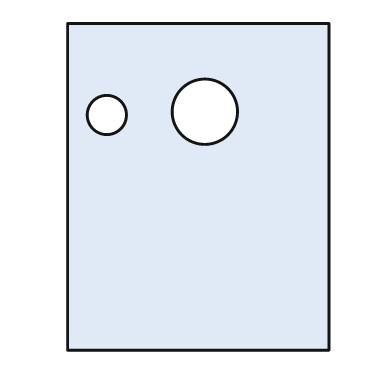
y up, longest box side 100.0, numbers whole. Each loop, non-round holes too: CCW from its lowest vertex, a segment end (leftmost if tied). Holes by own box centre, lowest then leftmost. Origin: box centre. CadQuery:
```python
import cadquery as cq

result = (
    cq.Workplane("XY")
    .moveTo(-40.0, -50.0)
    .lineTo(40.0, -50.0)
    .lineTo(40.0, 50.0)
    .lineTo(-40.0, 50.0)
    .close()
    .moveTo(-28.0, 22.0)
    .circle(6.0)
    .moveTo(2.0, 23.0)
    .circle(10.0)
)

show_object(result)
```